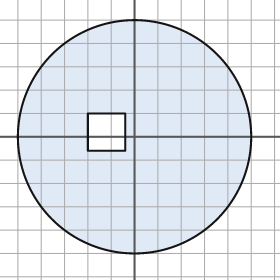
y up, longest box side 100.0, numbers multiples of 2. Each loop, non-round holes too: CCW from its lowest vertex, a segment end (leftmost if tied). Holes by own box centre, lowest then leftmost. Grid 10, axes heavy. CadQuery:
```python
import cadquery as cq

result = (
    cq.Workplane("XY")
    .moveTo(0.0, 0.0)
    .circle(50.0)
    .moveTo(-20.0, -6.0)
    .lineTo(-4.0, -6.0)
    .lineTo(-4.0, 10.0)
    .lineTo(-20.0, 10.0)
    .close()
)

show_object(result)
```